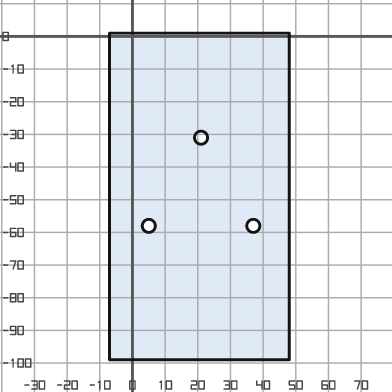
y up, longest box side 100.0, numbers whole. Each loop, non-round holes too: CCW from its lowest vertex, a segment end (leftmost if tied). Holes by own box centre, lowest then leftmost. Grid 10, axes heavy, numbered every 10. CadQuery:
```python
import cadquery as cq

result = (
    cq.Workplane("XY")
    .moveTo(-7.0, -99.0)
    .lineTo(48.0, -99.0)
    .lineTo(48.0, 1.0)
    .lineTo(-7.0, 1.0)
    .close()
    .moveTo(5.0, -58.0)
    .circle(2.0)
    .moveTo(37.0, -58.0)
    .circle(2.0)
    .moveTo(21.0, -31.0)
    .circle(2.0)
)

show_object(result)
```